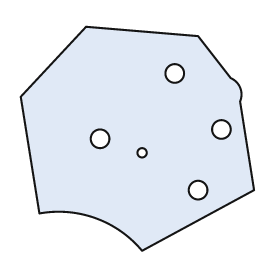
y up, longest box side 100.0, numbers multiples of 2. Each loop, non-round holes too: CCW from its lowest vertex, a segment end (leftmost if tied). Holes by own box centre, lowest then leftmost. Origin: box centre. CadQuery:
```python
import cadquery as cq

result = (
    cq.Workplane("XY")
    .moveTo(2.0, -48.0)
    .lineTo(50.0, -22.0)
    .lineTo(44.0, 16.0)
    .threePointArc((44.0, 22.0), (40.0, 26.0))
    .lineTo(26.0, 44.0)
    .lineTo(-22.0, 48.0)
    .lineTo(-50.0, 18.0)
    .lineTo(-42.0, -32.0)
    .threePointArc((-18.0, -34.0), (2.0, -48.0))
    .close()
    .moveTo(26.0, -22.0)
    .circle(4.0)
    .moveTo(2.0, -6.0)
    .circle(2.0)
    .moveTo(-16.0, 0.0)
    .circle(4.0)
    .moveTo(36.0, 4.0)
    .circle(4.0)
    .moveTo(16.0, 28.0)
    .circle(4.0)
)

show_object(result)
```